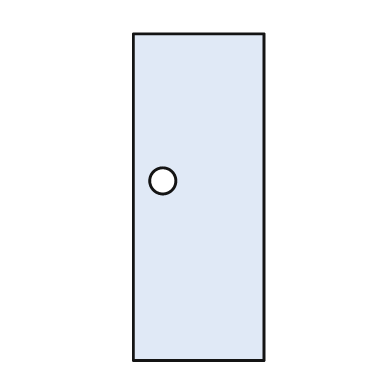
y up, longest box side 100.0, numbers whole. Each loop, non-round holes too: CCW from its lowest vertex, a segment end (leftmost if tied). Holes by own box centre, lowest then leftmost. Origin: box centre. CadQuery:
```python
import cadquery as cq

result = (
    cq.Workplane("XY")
    .moveTo(-20.0, -50.0)
    .lineTo(20.0, -50.0)
    .lineTo(20.0, 50.0)
    .lineTo(-20.0, 50.0)
    .close()
    .moveTo(-11.0, 5.0)
    .circle(4.0)
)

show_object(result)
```